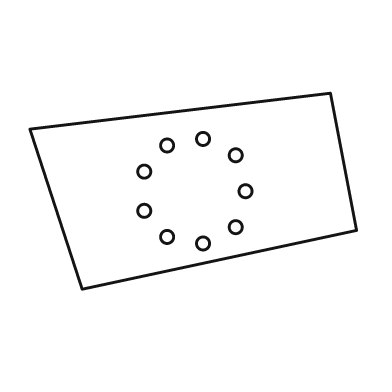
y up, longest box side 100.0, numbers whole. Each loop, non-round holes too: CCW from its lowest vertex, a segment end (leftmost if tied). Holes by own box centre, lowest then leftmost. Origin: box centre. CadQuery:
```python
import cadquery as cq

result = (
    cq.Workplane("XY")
    .moveTo(-34.0, -30.0)
    .lineTo(50.0, -12.0)
    .lineTo(42.0, 30.0)
    .lineTo(-50.0, 19.0)
    .close()
    .moveTo(3.0, -16.0)
    .circle(2.0)
    .moveTo(-8.0, -14.0)
    .circle(2.0)
    .moveTo(13.0, -11.0)
    .circle(2.0)
    .moveTo(-15.0, -6.0)
    .circle(2.0)
    .moveTo(16.0, 0.0)
    .circle(2.0)
    .moveTo(-15.0, 6.0)
    .circle(2.0)
    .moveTo(13.0, 11.0)
    .circle(2.0)
    .moveTo(-8.0, 14.0)
    .circle(2.0)
    .moveTo(3.0, 16.0)
    .circle(2.0)
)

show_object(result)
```